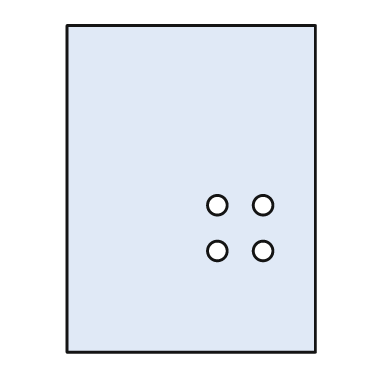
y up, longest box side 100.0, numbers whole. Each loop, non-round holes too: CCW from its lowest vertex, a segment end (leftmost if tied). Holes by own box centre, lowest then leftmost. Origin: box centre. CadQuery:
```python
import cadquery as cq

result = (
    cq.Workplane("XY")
    .moveTo(-38.0, -50.0)
    .lineTo(38.0, -50.0)
    .lineTo(38.0, 50.0)
    .lineTo(-38.0, 50.0)
    .close()
    .moveTo(8.0, -19.0)
    .circle(3.0)
    .moveTo(22.0, -19.0)
    .circle(3.0)
    .moveTo(8.0, -5.0)
    .circle(3.0)
    .moveTo(22.0, -5.0)
    .circle(3.0)
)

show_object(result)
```